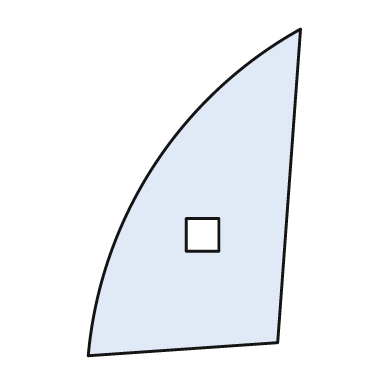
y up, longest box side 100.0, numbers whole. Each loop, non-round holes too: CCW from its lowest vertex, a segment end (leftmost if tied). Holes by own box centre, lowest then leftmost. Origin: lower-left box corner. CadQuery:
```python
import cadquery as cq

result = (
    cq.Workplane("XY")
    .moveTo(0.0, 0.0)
    .lineTo(58.0, 4.0)
    .lineTo(65.0, 100.0)
    .threePointArc((20.0, 58.0), (0.0, 0.0))
    .close()
    .moveTo(30.0, 32.0)
    .lineTo(40.0, 32.0)
    .lineTo(40.0, 42.0)
    .lineTo(30.0, 42.0)
    .close()
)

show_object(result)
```